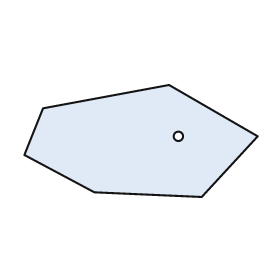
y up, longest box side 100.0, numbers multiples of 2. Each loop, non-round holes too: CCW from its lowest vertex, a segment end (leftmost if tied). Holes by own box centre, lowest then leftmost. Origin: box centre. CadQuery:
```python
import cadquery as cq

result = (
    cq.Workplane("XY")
    .moveTo(26.0, -24.0)
    .lineTo(50.0, 2.0)
    .lineTo(12.0, 24.0)
    .lineTo(-42.0, 14.0)
    .lineTo(-50.0, -6.0)
    .lineTo(-20.0, -22.0)
    .close()
    .moveTo(16.0, 2.0)
    .circle(2.0)
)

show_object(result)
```